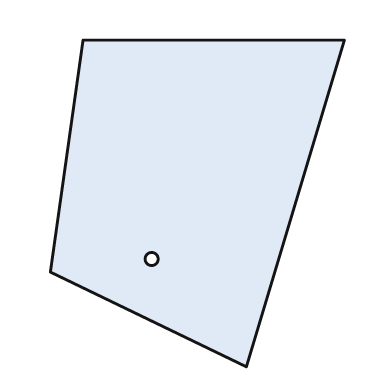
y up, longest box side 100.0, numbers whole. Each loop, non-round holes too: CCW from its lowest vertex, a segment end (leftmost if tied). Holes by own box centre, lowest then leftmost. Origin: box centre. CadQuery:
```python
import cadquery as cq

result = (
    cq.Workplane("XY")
    .moveTo(15.0, -50.0)
    .lineTo(45.0, 50.0)
    .lineTo(-35.0, 50.0)
    .lineTo(-45.0, -21.0)
    .close()
    .moveTo(-14.0, -17.0)
    .circle(2.0)
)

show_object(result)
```